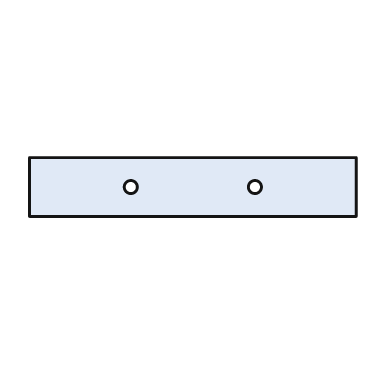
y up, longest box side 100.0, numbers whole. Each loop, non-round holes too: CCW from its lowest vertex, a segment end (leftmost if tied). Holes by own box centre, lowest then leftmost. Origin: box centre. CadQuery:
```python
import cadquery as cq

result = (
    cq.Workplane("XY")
    .moveTo(-50.0, -9.0)
    .lineTo(50.0, -9.0)
    .lineTo(50.0, 9.0)
    .lineTo(-50.0, 9.0)
    .close()
    .moveTo(-19.0, 0.0)
    .circle(2.0)
    .moveTo(19.0, 0.0)
    .circle(2.0)
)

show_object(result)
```